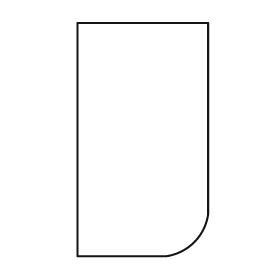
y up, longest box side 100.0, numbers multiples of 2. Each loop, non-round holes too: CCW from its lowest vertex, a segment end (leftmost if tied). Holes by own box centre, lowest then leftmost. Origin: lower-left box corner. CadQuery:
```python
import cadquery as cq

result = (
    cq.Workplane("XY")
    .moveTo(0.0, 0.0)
    .lineTo(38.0, 0.0)
    .threePointArc((50.0, 6.0), (56.0, 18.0))
    .lineTo(56.0, 100.0)
    .lineTo(0.0, 100.0)
    .close()
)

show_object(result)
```